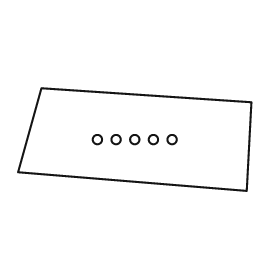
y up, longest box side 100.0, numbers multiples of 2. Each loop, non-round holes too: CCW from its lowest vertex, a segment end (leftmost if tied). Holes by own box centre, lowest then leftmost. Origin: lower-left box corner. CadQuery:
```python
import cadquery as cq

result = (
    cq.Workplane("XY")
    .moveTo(98.0, 0.0)
    .lineTo(100.0, 38.0)
    .lineTo(10.0, 44.0)
    .lineTo(0.0, 8.0)
    .close()
    .moveTo(34.0, 22.0)
    .circle(2.0)
    .moveTo(42.0, 22.0)
    .circle(2.0)
    .moveTo(50.0, 22.0)
    .circle(2.0)
    .moveTo(58.0, 22.0)
    .circle(2.0)
    .moveTo(66.0, 22.0)
    .circle(2.0)
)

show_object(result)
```